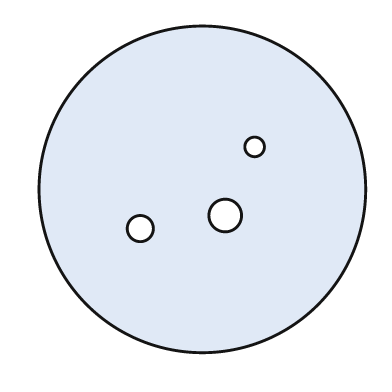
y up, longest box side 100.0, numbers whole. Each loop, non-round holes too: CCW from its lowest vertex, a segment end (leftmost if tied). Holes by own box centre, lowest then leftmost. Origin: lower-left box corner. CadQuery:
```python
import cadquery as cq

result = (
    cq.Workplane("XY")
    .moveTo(50.0, 50.0)
    .circle(50.0)
    .moveTo(31.0, 38.0)
    .circle(4.0)
    .moveTo(57.0, 42.0)
    .circle(5.0)
    .moveTo(66.0, 63.0)
    .circle(3.0)
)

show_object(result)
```